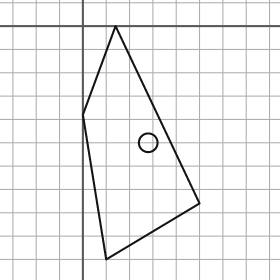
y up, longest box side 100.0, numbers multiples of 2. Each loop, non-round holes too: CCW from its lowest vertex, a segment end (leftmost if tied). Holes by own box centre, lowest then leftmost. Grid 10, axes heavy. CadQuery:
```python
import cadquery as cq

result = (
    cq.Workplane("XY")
    .moveTo(10.0, -100.0)
    .lineTo(50.0, -76.0)
    .lineTo(14.0, 0.0)
    .lineTo(0.0, -38.0)
    .close()
    .moveTo(28.0, -50.0)
    .circle(4.0)
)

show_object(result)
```